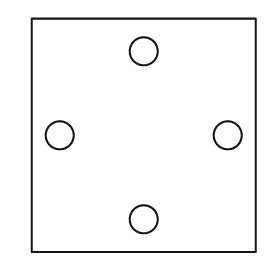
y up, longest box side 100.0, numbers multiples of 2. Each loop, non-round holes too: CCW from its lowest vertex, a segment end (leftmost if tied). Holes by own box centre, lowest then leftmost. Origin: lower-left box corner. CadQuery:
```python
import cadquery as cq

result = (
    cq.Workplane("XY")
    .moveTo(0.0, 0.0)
    .lineTo(96.0, 0.0)
    .lineTo(96.0, 100.0)
    .lineTo(0.0, 100.0)
    .close()
    .moveTo(48.0, 14.0)
    .circle(6.0)
    .moveTo(12.0, 50.0)
    .circle(6.0)
    .moveTo(84.0, 50.0)
    .circle(6.0)
    .moveTo(48.0, 86.0)
    .circle(6.0)
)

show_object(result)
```